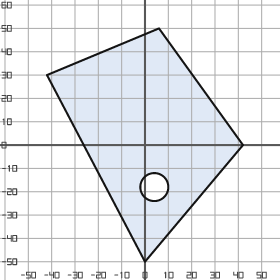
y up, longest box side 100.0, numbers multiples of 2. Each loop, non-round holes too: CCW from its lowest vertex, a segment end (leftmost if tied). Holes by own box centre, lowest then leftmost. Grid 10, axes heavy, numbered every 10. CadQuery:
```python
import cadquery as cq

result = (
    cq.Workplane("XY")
    .moveTo(0.0, -50.0)
    .lineTo(42.0, 0.0)
    .lineTo(6.0, 50.0)
    .lineTo(-42.0, 30.0)
    .close()
    .moveTo(4.0, -18.0)
    .circle(6.0)
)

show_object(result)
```